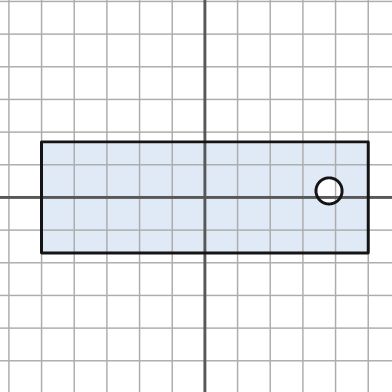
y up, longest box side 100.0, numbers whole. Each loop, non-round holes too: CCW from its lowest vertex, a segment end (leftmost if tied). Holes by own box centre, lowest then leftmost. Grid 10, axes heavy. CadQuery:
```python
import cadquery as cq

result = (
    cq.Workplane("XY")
    .moveTo(-50.0, -17.0)
    .lineTo(50.0, -17.0)
    .lineTo(50.0, 17.0)
    .lineTo(-50.0, 17.0)
    .close()
    .moveTo(38.0, 2.0)
    .circle(4.0)
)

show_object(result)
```